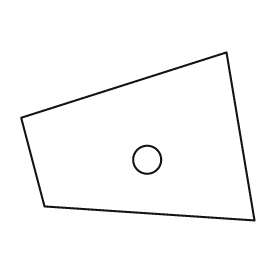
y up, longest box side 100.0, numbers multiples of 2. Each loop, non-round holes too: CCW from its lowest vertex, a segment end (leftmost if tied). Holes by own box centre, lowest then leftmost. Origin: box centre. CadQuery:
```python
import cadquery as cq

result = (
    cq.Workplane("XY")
    .moveTo(50.0, -36.0)
    .lineTo(38.0, 36.0)
    .lineTo(-50.0, 8.0)
    .lineTo(-40.0, -30.0)
    .close()
    .moveTo(4.0, -10.0)
    .circle(6.0)
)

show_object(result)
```